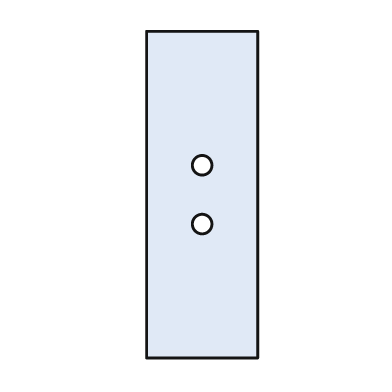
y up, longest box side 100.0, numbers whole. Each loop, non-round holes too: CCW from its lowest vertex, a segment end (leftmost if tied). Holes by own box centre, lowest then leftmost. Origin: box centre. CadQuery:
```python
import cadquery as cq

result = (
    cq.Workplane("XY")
    .moveTo(-17.0, -50.0)
    .lineTo(17.0, -50.0)
    .lineTo(17.0, 50.0)
    .lineTo(-17.0, 50.0)
    .close()
    .moveTo(0.0, -9.0)
    .circle(3.0)
    .moveTo(0.0, 9.0)
    .circle(3.0)
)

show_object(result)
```